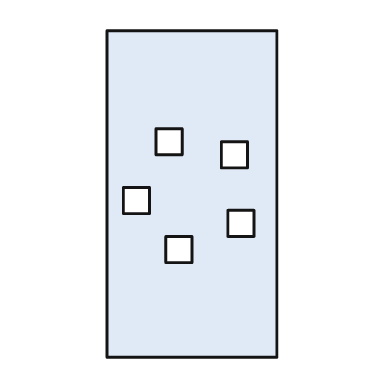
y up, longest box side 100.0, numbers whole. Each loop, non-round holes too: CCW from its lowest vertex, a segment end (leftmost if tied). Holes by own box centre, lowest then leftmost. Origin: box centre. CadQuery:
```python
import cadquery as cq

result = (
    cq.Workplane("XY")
    .moveTo(-26.0, -50.0)
    .lineTo(26.0, -50.0)
    .lineTo(26.0, 50.0)
    .lineTo(-26.0, 50.0)
    .close()
    .moveTo(-8.0, -21.0)
    .lineTo(0.0, -21.0)
    .lineTo(0.0, -13.0)
    .lineTo(-8.0, -13.0)
    .close()
    .moveTo(11.0, -13.0)
    .lineTo(19.0, -13.0)
    .lineTo(19.0, -5.0)
    .lineTo(11.0, -5.0)
    .close()
    .moveTo(-21.0, -6.0)
    .lineTo(-13.0, -6.0)
    .lineTo(-13.0, 2.0)
    .lineTo(-21.0, 2.0)
    .close()
    .moveTo(9.0, 8.0)
    .lineTo(17.0, 8.0)
    .lineTo(17.0, 16.0)
    .lineTo(9.0, 16.0)
    .close()
    .moveTo(-11.0, 12.0)
    .lineTo(-3.0, 12.0)
    .lineTo(-3.0, 20.0)
    .lineTo(-11.0, 20.0)
    .close()
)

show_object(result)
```